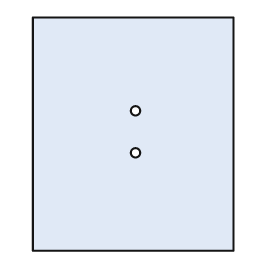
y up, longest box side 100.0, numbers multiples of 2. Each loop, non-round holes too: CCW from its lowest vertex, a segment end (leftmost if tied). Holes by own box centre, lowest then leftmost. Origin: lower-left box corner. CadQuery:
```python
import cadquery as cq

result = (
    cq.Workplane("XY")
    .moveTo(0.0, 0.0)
    .lineTo(86.0, 0.0)
    .lineTo(86.0, 100.0)
    .lineTo(0.0, 100.0)
    .close()
    .moveTo(44.0, 42.0)
    .circle(2.0)
    .moveTo(44.0, 60.0)
    .circle(2.0)
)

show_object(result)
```